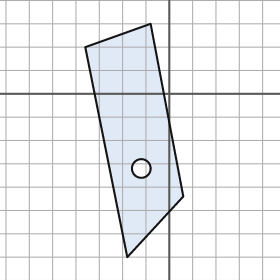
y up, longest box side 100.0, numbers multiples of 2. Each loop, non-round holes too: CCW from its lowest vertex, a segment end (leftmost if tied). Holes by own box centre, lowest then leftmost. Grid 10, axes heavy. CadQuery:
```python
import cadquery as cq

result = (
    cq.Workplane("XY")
    .moveTo(-18.0, -70.0)
    .lineTo(6.0, -44.0)
    .lineTo(-8.0, 30.0)
    .lineTo(-36.0, 20.0)
    .close()
    .moveTo(-12.0, -32.0)
    .circle(4.0)
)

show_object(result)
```